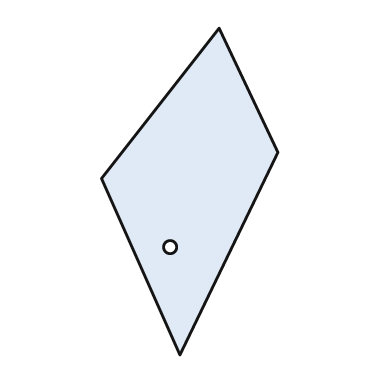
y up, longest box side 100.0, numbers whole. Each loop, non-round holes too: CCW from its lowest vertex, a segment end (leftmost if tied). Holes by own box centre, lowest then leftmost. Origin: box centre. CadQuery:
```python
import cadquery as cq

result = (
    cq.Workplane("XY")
    .moveTo(-3.0, -50.0)
    .lineTo(27.0, 12.0)
    .lineTo(9.0, 50.0)
    .lineTo(-27.0, 4.0)
    .close()
    .moveTo(-6.0, -17.0)
    .circle(2.0)
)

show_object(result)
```